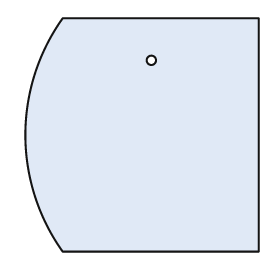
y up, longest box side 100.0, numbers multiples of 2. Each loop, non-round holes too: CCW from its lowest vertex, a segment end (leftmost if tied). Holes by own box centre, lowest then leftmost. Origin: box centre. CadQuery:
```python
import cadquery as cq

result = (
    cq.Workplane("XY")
    .moveTo(-34.0, -50.0)
    .lineTo(50.0, -50.0)
    .lineTo(50.0, 50.0)
    .lineTo(-34.0, 50.0)
    .threePointArc((-50.0, 0.0), (-34.0, -50.0))
    .close()
    .moveTo(4.0, 32.0)
    .circle(2.0)
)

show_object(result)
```